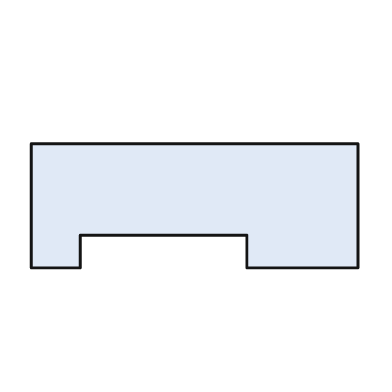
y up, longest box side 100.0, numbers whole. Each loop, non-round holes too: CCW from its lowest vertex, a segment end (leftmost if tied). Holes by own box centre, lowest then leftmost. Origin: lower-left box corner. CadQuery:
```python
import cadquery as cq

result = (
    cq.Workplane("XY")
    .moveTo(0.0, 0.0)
    .lineTo(15.0, 0.0)
    .lineTo(15.0, 10.0)
    .lineTo(66.0, 10.0)
    .lineTo(66.0, 0.0)
    .lineTo(100.0, 0.0)
    .lineTo(100.0, 38.0)
    .lineTo(0.0, 38.0)
    .close()
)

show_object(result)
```